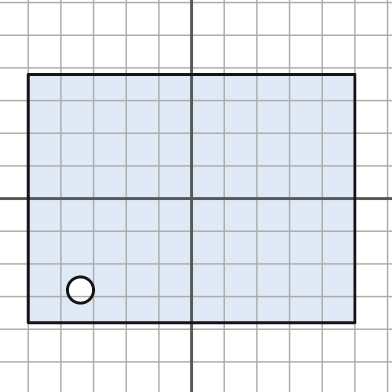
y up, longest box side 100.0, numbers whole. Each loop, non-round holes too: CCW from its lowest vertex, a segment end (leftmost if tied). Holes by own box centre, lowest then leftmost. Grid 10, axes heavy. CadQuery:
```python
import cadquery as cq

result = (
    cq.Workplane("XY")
    .moveTo(-50.0, -38.0)
    .lineTo(50.0, -38.0)
    .lineTo(50.0, 38.0)
    .lineTo(-50.0, 38.0)
    .close()
    .moveTo(-34.0, -28.0)
    .circle(4.0)
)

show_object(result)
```